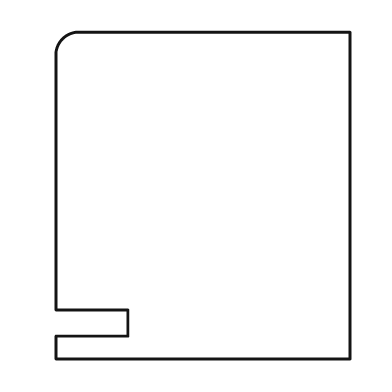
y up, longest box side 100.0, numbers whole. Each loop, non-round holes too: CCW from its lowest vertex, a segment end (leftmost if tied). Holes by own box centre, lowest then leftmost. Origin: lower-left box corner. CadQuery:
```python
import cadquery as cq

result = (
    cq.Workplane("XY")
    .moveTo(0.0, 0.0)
    .lineTo(90.0, 0.0)
    .lineTo(90.0, 100.0)
    .lineTo(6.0, 100.0)
    .threePointArc((2.0, 98.0), (0.0, 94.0))
    .lineTo(0.0, 15.0)
    .lineTo(22.0, 15.0)
    .lineTo(22.0, 7.0)
    .lineTo(0.0, 7.0)
    .close()
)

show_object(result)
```